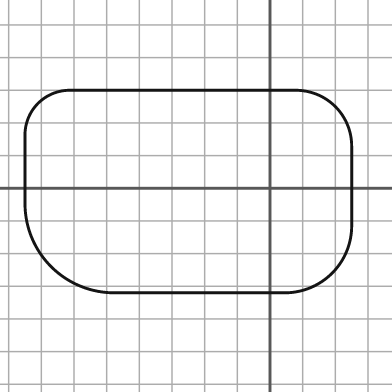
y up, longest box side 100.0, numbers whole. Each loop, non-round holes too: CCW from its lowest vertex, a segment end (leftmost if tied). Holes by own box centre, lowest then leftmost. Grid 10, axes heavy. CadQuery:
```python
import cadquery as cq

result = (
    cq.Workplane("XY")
    .moveTo(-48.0, -32.0)
    .lineTo(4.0, -32.0)
    .threePointArc((19.0, -26.0), (25.0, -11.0))
    .lineTo(25.0, 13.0)
    .threePointArc((20.0, 25.0), (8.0, 30.0))
    .lineTo(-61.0, 30.0)
    .threePointArc((-71.0, 26.0), (-75.0, 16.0))
    .lineTo(-75.0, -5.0)
    .threePointArc((-67.0, -24.0), (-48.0, -32.0))
    .close()
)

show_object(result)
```